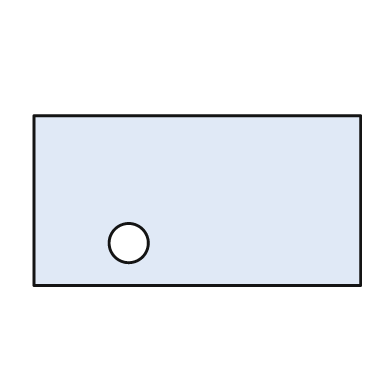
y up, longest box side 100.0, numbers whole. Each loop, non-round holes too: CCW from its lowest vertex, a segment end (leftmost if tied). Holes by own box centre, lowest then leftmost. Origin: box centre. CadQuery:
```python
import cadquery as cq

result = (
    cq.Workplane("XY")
    .moveTo(-50.0, -26.0)
    .lineTo(50.0, -26.0)
    .lineTo(50.0, 26.0)
    .lineTo(-50.0, 26.0)
    .close()
    .moveTo(-21.0, -13.0)
    .circle(6.0)
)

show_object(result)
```